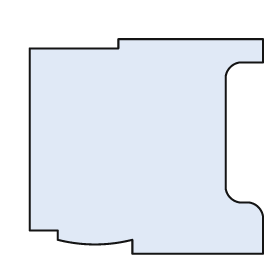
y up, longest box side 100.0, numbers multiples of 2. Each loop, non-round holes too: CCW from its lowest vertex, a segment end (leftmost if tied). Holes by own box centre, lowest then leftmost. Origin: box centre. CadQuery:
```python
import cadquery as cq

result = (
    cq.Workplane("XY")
    .moveTo(-6.0, -46.0)
    .lineTo(50.0, -46.0)
    .lineTo(50.0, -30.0)
    .threePointArc((48.0, -26.0), (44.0, -24.0))
    .lineTo(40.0, -24.0)
    .threePointArc((36.0, -22.0), (34.0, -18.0))
    .lineTo(34.0, 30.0)
    .threePointArc((36.0, 34.0), (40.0, 36.0))
    .lineTo(50.0, 36.0)
    .lineTo(50.0, 46.0)
    .lineTo(-12.0, 46.0)
    .lineTo(-12.0, 42.0)
    .lineTo(-50.0, 42.0)
    .lineTo(-50.0, -36.0)
    .lineTo(-38.0, -36.0)
    .lineTo(-38.0, -40.0)
    .threePointArc((-22.0, -42.0), (-6.0, -40.0))
    .close()
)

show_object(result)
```